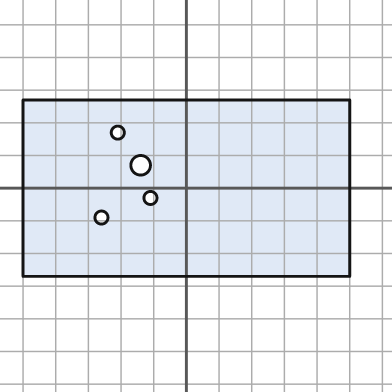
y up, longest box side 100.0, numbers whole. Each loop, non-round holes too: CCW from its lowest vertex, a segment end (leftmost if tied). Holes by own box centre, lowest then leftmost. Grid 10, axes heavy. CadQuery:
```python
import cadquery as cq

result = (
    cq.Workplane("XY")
    .moveTo(-50.0, -27.0)
    .lineTo(50.0, -27.0)
    .lineTo(50.0, 27.0)
    .lineTo(-50.0, 27.0)
    .close()
    .moveTo(-26.0, -9.0)
    .circle(2.0)
    .moveTo(-11.0, -3.0)
    .circle(2.0)
    .moveTo(-14.0, 7.0)
    .circle(3.0)
    .moveTo(-21.0, 17.0)
    .circle(2.0)
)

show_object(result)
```